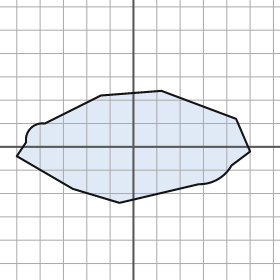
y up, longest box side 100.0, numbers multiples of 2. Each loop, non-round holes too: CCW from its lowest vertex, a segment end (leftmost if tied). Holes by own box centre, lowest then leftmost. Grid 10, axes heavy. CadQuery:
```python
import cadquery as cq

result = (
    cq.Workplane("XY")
    .moveTo(-6.0, -24.0)
    .lineTo(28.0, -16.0)
    .threePointArc((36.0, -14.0), (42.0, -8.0))
    .lineTo(50.0, -2.0)
    .lineTo(44.0, 12.0)
    .lineTo(12.0, 24.0)
    .lineTo(-14.0, 22.0)
    .lineTo(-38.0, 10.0)
    .threePointArc((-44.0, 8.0), (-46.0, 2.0))
    .lineTo(-50.0, -4.0)
    .lineTo(-26.0, -18.0)
    .close()
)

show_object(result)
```